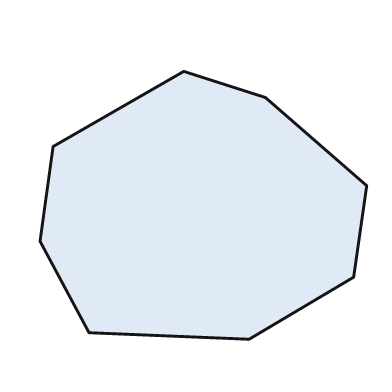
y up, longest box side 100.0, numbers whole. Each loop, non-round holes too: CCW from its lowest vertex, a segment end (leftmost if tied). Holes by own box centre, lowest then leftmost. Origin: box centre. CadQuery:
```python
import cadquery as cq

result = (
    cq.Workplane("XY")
    .moveTo(14.0, -41.0)
    .lineTo(46.0, -22.0)
    .lineTo(50.0, 6.0)
    .lineTo(19.0, 33.0)
    .lineTo(-6.0, 41.0)
    .lineTo(-46.0, 18.0)
    .lineTo(-50.0, -11.0)
    .lineTo(-35.0, -39.0)
    .close()
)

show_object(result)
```